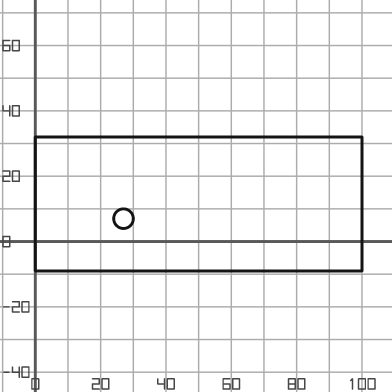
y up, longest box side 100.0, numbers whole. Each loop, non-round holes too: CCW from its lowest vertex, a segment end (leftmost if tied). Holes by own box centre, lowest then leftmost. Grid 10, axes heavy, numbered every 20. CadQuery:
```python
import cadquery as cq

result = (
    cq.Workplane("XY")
    .moveTo(0.0, -9.0)
    .lineTo(100.0, -9.0)
    .lineTo(100.0, 32.0)
    .lineTo(0.0, 32.0)
    .close()
    .moveTo(27.0, 7.0)
    .circle(3.0)
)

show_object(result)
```